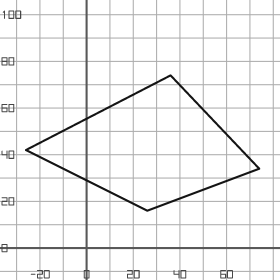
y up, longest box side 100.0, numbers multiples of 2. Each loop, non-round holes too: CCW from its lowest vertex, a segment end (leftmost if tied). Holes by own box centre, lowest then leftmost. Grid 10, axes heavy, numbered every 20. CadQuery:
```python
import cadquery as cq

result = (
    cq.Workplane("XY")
    .moveTo(26.0, 16.0)
    .lineTo(74.0, 34.0)
    .lineTo(36.0, 74.0)
    .lineTo(-26.0, 42.0)
    .close()
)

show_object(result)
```